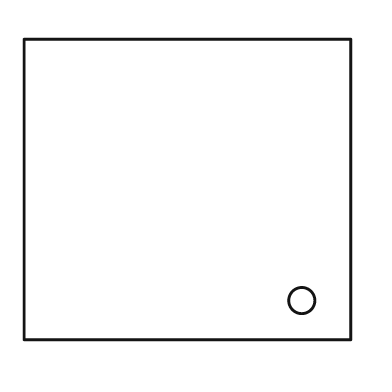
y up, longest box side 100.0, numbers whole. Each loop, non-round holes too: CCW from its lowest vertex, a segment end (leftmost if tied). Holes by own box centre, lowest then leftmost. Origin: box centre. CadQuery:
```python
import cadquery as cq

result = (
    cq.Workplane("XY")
    .moveTo(-50.0, -46.0)
    .lineTo(50.0, -46.0)
    .lineTo(50.0, 46.0)
    .lineTo(-50.0, 46.0)
    .close()
    .moveTo(35.0, -34.0)
    .circle(4.0)
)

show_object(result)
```